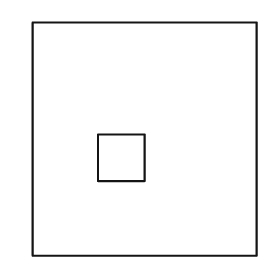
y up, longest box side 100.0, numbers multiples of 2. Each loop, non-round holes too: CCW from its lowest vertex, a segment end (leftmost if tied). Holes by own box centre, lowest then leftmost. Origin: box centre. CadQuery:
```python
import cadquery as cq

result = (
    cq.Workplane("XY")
    .moveTo(-48.0, -50.0)
    .lineTo(48.0, -50.0)
    .lineTo(48.0, 50.0)
    .lineTo(-48.0, 50.0)
    .close()
    .moveTo(-20.0, -18.0)
    .lineTo(0.0, -18.0)
    .lineTo(0.0, 2.0)
    .lineTo(-20.0, 2.0)
    .close()
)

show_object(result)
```